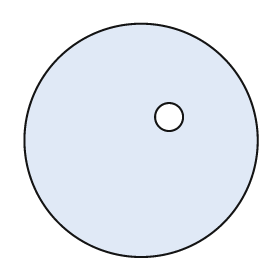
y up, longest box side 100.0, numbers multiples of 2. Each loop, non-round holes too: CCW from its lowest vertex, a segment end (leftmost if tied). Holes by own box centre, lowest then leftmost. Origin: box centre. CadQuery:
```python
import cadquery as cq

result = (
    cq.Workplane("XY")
    .moveTo(0.0, 0.0)
    .circle(50.0)
    .moveTo(12.0, 10.0)
    .circle(6.0)
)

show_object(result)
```